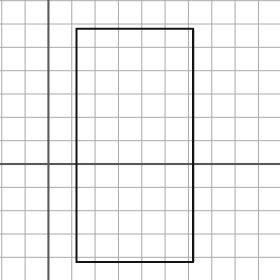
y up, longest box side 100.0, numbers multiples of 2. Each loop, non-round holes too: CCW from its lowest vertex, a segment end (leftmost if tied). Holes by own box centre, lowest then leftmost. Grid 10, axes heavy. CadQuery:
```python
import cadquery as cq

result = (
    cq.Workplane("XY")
    .moveTo(12.0, -42.0)
    .lineTo(62.0, -42.0)
    .lineTo(62.0, 58.0)
    .lineTo(12.0, 58.0)
    .close()
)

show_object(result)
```